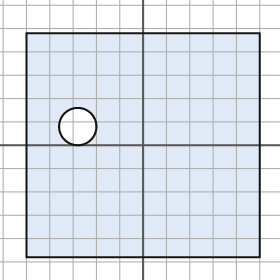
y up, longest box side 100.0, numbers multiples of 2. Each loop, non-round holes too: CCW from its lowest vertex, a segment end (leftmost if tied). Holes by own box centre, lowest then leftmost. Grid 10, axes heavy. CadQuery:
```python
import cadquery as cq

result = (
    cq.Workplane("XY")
    .moveTo(-50.0, -48.0)
    .lineTo(50.0, -48.0)
    .lineTo(50.0, 48.0)
    .lineTo(-50.0, 48.0)
    .close()
    .moveTo(-28.0, 8.0)
    .circle(8.0)
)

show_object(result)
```